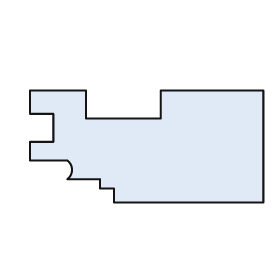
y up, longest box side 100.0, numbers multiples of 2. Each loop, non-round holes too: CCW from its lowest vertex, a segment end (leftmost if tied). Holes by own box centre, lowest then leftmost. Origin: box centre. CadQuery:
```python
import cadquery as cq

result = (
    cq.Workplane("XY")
    .moveTo(-14.0, -24.0)
    .lineTo(50.0, -24.0)
    .lineTo(50.0, 24.0)
    .lineTo(6.0, 24.0)
    .lineTo(6.0, 12.0)
    .lineTo(-26.0, 12.0)
    .lineTo(-26.0, 24.0)
    .lineTo(-50.0, 24.0)
    .lineTo(-50.0, 14.0)
    .lineTo(-40.0, 14.0)
    .lineTo(-40.0, 2.0)
    .lineTo(-50.0, 2.0)
    .lineTo(-50.0, -6.0)
    .lineTo(-34.0, -6.0)
    .threePointArc((-32.0, -10.0), (-34.0, -14.0))
    .lineTo(-20.0, -14.0)
    .lineTo(-20.0, -18.0)
    .lineTo(-14.0, -18.0)
    .close()
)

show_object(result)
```